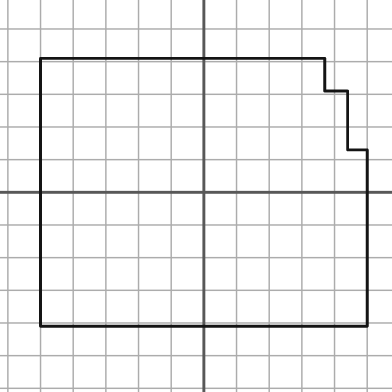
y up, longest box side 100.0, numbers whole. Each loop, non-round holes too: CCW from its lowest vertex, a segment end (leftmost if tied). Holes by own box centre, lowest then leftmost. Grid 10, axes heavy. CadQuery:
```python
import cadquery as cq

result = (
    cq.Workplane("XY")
    .moveTo(-50.0, -41.0)
    .lineTo(50.0, -41.0)
    .lineTo(50.0, 13.0)
    .lineTo(44.0, 13.0)
    .lineTo(44.0, 31.0)
    .lineTo(37.0, 31.0)
    .lineTo(37.0, 41.0)
    .lineTo(-50.0, 41.0)
    .close()
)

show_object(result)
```